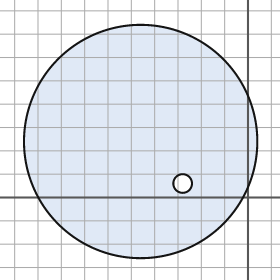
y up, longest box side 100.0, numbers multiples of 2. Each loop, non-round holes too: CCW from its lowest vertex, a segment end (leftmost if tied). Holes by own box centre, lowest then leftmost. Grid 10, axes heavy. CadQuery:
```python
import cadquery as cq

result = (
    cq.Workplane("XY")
    .moveTo(-46.0, 24.0)
    .circle(50.0)
    .moveTo(-28.0, 6.0)
    .circle(4.0)
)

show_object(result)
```